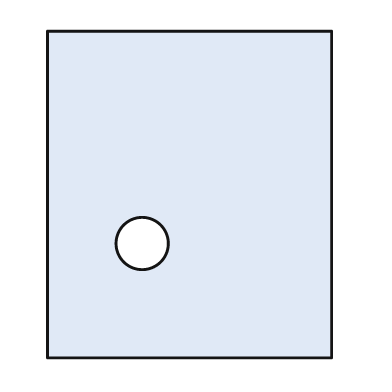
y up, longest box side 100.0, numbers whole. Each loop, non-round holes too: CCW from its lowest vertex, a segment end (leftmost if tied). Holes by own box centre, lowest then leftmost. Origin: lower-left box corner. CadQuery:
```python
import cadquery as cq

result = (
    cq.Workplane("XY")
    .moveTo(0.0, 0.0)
    .lineTo(87.0, 0.0)
    .lineTo(87.0, 100.0)
    .lineTo(0.0, 100.0)
    .close()
    .moveTo(29.0, 35.0)
    .circle(8.0)
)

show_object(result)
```